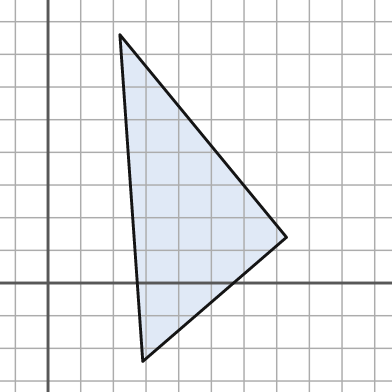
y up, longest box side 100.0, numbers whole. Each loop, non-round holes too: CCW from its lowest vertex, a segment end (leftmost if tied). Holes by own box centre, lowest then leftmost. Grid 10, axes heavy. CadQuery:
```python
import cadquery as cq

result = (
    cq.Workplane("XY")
    .moveTo(29.0, -24.0)
    .lineTo(73.0, 14.0)
    .lineTo(22.0, 76.0)
    .close()
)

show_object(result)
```